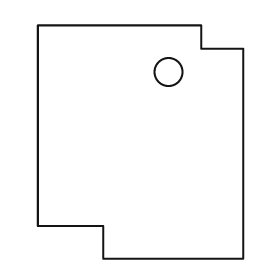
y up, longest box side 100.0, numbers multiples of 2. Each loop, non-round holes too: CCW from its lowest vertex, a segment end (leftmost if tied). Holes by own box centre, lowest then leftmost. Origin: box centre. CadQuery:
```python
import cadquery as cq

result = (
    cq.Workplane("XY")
    .moveTo(-16.0, -50.0)
    .lineTo(44.0, -50.0)
    .lineTo(44.0, 40.0)
    .lineTo(26.0, 40.0)
    .lineTo(26.0, 50.0)
    .lineTo(-44.0, 50.0)
    .lineTo(-44.0, -36.0)
    .lineTo(-16.0, -36.0)
    .close()
    .moveTo(12.0, 30.0)
    .circle(6.0)
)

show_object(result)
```